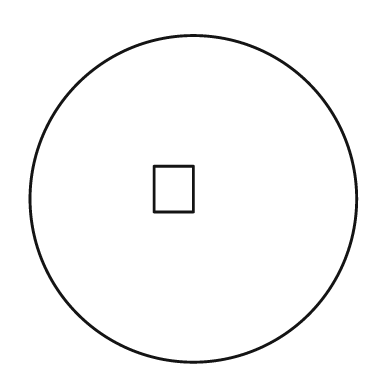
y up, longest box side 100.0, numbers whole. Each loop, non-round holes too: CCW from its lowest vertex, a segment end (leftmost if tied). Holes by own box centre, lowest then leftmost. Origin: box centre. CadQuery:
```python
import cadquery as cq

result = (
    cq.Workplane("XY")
    .moveTo(0.0, 0.0)
    .circle(50.0)
    .moveTo(-12.0, -4.0)
    .lineTo(0.0, -4.0)
    .lineTo(0.0, 10.0)
    .lineTo(-12.0, 10.0)
    .close()
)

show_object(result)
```